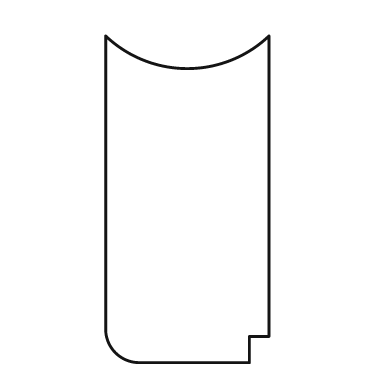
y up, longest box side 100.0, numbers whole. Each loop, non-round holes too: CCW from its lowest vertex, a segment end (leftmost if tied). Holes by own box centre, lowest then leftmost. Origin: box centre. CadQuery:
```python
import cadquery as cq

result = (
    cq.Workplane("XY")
    .moveTo(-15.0, -50.0)
    .lineTo(19.0, -50.0)
    .lineTo(19.0, -42.0)
    .lineTo(25.0, -42.0)
    .lineTo(25.0, 50.0)
    .threePointArc((0.0, 40.0), (-25.0, 50.0))
    .lineTo(-25.0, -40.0)
    .threePointArc((-22.0, -47.0), (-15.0, -50.0))
    .close()
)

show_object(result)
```